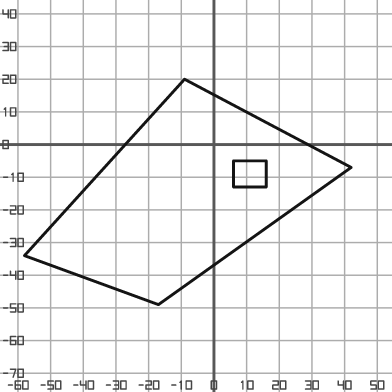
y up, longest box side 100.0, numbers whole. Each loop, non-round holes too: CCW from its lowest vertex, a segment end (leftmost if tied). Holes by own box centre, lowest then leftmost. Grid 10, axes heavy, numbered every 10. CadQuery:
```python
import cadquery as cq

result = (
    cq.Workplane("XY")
    .moveTo(-17.0, -49.0)
    .lineTo(42.0, -7.0)
    .lineTo(-9.0, 20.0)
    .lineTo(-58.0, -34.0)
    .close()
    .moveTo(6.0, -13.0)
    .lineTo(16.0, -13.0)
    .lineTo(16.0, -5.0)
    .lineTo(6.0, -5.0)
    .close()
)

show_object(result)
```